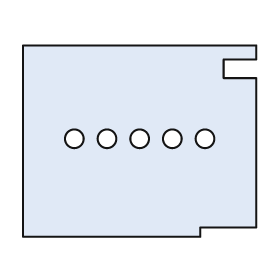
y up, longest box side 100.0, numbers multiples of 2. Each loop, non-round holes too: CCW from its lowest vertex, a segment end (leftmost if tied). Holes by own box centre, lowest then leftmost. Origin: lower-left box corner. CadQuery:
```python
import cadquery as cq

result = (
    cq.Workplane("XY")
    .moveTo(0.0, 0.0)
    .lineTo(76.0, 0.0)
    .lineTo(76.0, 4.0)
    .lineTo(100.0, 4.0)
    .lineTo(100.0, 68.0)
    .lineTo(86.0, 68.0)
    .lineTo(86.0, 76.0)
    .lineTo(100.0, 76.0)
    .lineTo(100.0, 82.0)
    .lineTo(0.0, 82.0)
    .close()
    .moveTo(22.0, 42.0)
    .circle(4.0)
    .moveTo(36.0, 42.0)
    .circle(4.0)
    .moveTo(50.0, 42.0)
    .circle(4.0)
    .moveTo(64.0, 42.0)
    .circle(4.0)
    .moveTo(78.0, 42.0)
    .circle(4.0)
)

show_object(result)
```